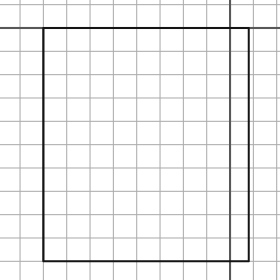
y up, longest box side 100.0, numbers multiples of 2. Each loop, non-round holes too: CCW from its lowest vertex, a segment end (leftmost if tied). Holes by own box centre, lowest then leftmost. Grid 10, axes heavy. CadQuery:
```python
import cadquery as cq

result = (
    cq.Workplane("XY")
    .moveTo(-80.0, -100.0)
    .lineTo(8.0, -100.0)
    .lineTo(8.0, 0.0)
    .lineTo(-80.0, 0.0)
    .close()
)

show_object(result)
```